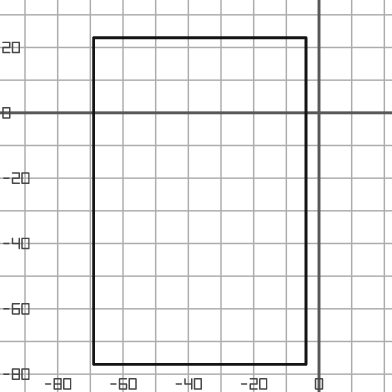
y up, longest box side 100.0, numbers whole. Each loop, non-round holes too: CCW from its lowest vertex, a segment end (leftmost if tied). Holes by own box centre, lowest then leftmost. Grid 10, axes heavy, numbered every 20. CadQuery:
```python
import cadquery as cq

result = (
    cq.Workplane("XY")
    .moveTo(-69.0, -77.0)
    .lineTo(-4.0, -77.0)
    .lineTo(-4.0, 23.0)
    .lineTo(-69.0, 23.0)
    .close()
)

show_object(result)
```